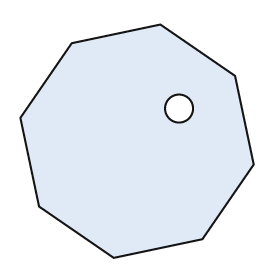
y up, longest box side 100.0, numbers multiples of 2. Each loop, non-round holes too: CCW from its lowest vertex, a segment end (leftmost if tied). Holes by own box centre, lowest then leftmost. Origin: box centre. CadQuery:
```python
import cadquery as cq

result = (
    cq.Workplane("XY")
    .moveTo(-10.0, -50.0)
    .lineTo(28.0, -42.0)
    .lineTo(50.0, -10.0)
    .lineTo(42.0, 28.0)
    .lineTo(10.0, 50.0)
    .lineTo(-28.0, 42.0)
    .lineTo(-50.0, 10.0)
    .lineTo(-42.0, -28.0)
    .close()
    .moveTo(18.0, 14.0)
    .circle(6.0)
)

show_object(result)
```